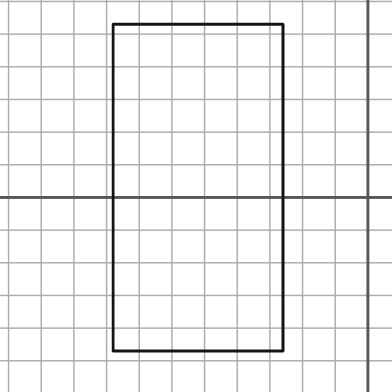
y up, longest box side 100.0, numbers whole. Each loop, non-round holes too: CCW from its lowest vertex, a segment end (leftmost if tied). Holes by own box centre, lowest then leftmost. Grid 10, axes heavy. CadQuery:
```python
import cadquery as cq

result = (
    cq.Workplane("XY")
    .moveTo(-78.0, -47.0)
    .lineTo(-26.0, -47.0)
    .lineTo(-26.0, 53.0)
    .lineTo(-78.0, 53.0)
    .close()
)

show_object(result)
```